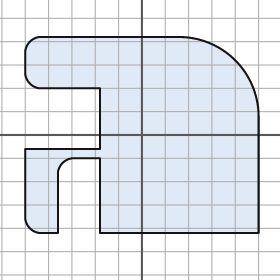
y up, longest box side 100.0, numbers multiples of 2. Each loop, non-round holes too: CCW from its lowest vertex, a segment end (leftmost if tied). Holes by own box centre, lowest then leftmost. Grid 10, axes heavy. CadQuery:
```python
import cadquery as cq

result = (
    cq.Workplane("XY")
    .moveTo(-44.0, -42.0)
    .lineTo(-36.0, -42.0)
    .lineTo(-36.0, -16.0)
    .threePointArc((-34.0, -12.0), (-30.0, -10.0))
    .lineTo(-18.0, -10.0)
    .lineTo(-18.0, -42.0)
    .lineTo(50.0, -42.0)
    .lineTo(50.0, 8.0)
    .threePointArc((40.0, 32.0), (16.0, 42.0))
    .lineTo(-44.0, 42.0)
    .threePointArc((-48.0, 40.0), (-50.0, 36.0))
    .lineTo(-50.0, 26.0)
    .threePointArc((-48.0, 22.0), (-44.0, 20.0))
    .lineTo(-18.0, 20.0)
    .lineTo(-18.0, -6.0)
    .lineTo(-50.0, -6.0)
    .lineTo(-50.0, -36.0)
    .threePointArc((-48.0, -40.0), (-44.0, -42.0))
    .close()
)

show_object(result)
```